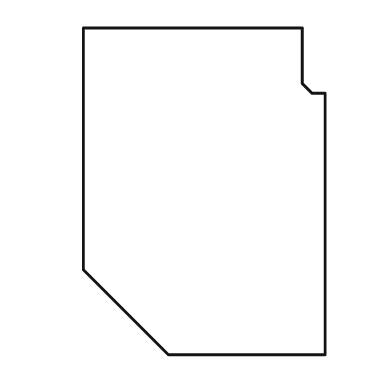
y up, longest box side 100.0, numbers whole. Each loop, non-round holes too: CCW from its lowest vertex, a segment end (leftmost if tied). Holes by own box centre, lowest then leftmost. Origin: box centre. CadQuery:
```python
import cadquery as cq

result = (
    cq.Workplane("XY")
    .moveTo(-11.0, -50.0)
    .lineTo(37.0, -50.0)
    .lineTo(37.0, 30.0)
    .lineTo(33.0, 30.0)
    .lineTo(30.0, 33.0)
    .lineTo(30.0, 50.0)
    .lineTo(-37.0, 50.0)
    .lineTo(-37.0, -24.0)
    .close()
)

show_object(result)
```